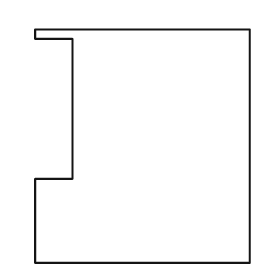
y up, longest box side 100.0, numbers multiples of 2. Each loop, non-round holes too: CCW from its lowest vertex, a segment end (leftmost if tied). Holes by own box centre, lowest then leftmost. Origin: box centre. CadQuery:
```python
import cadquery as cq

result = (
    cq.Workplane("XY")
    .moveTo(-46.0, -50.0)
    .lineTo(46.0, -50.0)
    .lineTo(46.0, 50.0)
    .lineTo(-46.0, 50.0)
    .lineTo(-46.0, 46.0)
    .lineTo(-30.0, 46.0)
    .lineTo(-30.0, -14.0)
    .lineTo(-46.0, -14.0)
    .close()
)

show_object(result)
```